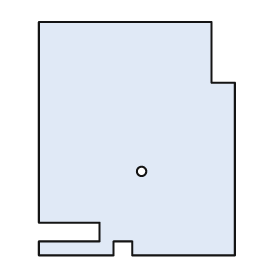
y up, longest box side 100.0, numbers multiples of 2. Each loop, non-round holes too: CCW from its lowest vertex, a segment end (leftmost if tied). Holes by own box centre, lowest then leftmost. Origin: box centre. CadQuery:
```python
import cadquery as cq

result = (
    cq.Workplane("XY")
    .moveTo(-42.0, -50.0)
    .lineTo(-10.0, -50.0)
    .lineTo(-10.0, -44.0)
    .lineTo(-2.0, -44.0)
    .lineTo(-2.0, -50.0)
    .lineTo(42.0, -50.0)
    .lineTo(42.0, 24.0)
    .lineTo(32.0, 24.0)
    .lineTo(32.0, 50.0)
    .lineTo(-42.0, 50.0)
    .lineTo(-42.0, -36.0)
    .lineTo(-16.0, -36.0)
    .lineTo(-16.0, -44.0)
    .lineTo(-42.0, -44.0)
    .close()
    .moveTo(2.0, -14.0)
    .circle(2.0)
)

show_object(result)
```